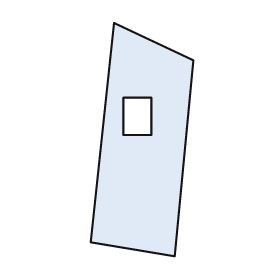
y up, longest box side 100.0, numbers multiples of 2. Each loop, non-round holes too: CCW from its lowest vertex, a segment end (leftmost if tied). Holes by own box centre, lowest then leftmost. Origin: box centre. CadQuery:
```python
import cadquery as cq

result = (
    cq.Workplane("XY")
    .moveTo(14.0, -50.0)
    .lineTo(22.0, 34.0)
    .lineTo(-12.0, 50.0)
    .lineTo(-22.0, -44.0)
    .close()
    .moveTo(-8.0, 2.0)
    .lineTo(4.0, 2.0)
    .lineTo(4.0, 18.0)
    .lineTo(-8.0, 18.0)
    .close()
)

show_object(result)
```